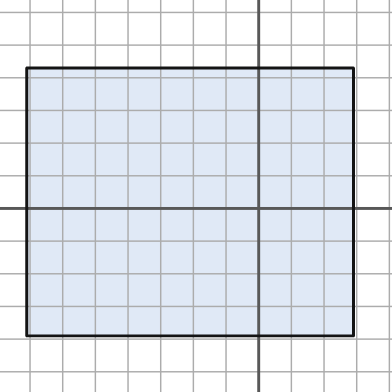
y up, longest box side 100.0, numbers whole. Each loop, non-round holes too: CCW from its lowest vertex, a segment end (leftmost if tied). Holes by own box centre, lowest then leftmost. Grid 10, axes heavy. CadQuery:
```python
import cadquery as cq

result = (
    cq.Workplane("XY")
    .moveTo(-71.0, -39.0)
    .lineTo(29.0, -39.0)
    .lineTo(29.0, 43.0)
    .lineTo(-71.0, 43.0)
    .close()
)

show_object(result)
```